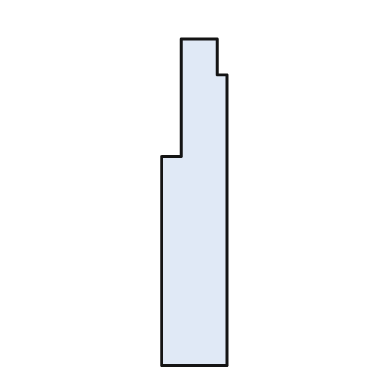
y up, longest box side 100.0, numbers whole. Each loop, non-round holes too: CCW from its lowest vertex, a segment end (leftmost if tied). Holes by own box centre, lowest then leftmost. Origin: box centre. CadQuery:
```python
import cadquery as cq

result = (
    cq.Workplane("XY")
    .moveTo(-10.0, -50.0)
    .lineTo(10.0, -50.0)
    .lineTo(10.0, 39.0)
    .lineTo(7.0, 39.0)
    .lineTo(7.0, 50.0)
    .lineTo(-4.0, 50.0)
    .lineTo(-4.0, 14.0)
    .lineTo(-10.0, 14.0)
    .close()
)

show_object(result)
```